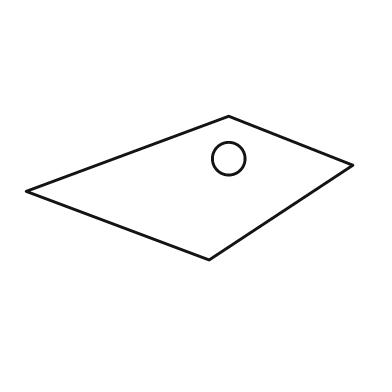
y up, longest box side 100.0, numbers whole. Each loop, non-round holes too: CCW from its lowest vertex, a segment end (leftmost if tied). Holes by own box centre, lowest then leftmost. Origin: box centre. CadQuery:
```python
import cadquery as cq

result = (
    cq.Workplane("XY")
    .moveTo(6.0, -22.0)
    .lineTo(50.0, 7.0)
    .lineTo(12.0, 22.0)
    .lineTo(-50.0, -1.0)
    .close()
    .moveTo(12.0, 9.0)
    .circle(5.0)
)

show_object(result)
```